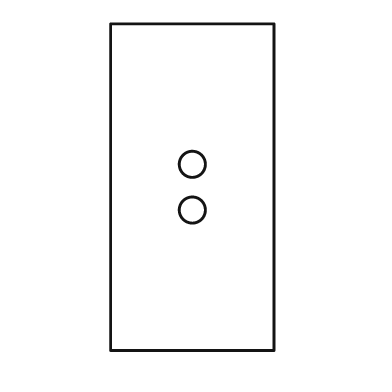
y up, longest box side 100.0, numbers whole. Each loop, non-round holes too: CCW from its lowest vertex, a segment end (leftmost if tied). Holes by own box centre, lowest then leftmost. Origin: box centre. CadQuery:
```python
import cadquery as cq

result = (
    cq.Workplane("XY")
    .moveTo(-25.0, -50.0)
    .lineTo(25.0, -50.0)
    .lineTo(25.0, 50.0)
    .lineTo(-25.0, 50.0)
    .close()
    .moveTo(0.0, -7.0)
    .circle(4.0)
    .moveTo(0.0, 7.0)
    .circle(4.0)
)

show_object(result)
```